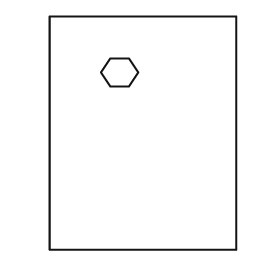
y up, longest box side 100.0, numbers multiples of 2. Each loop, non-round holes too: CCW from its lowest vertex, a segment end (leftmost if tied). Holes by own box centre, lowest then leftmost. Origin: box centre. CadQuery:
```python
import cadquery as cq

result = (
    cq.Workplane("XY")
    .moveTo(-40.0, -50.0)
    .lineTo(40.0, -50.0)
    .lineTo(40.0, 50.0)
    .lineTo(-40.0, 50.0)
    .close()
    .moveTo(-14.0, 20.0)
    .lineTo(-6.0, 20.0)
    .lineTo(-2.0, 26.0)
    .lineTo(-6.0, 32.0)
    .lineTo(-14.0, 32.0)
    .lineTo(-18.0, 26.0)
    .close()
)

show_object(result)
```